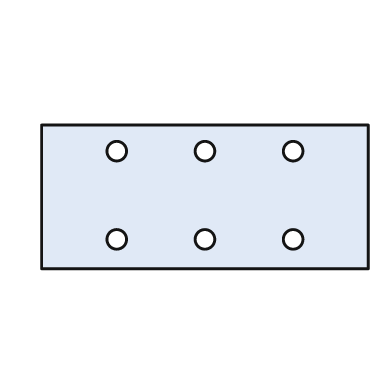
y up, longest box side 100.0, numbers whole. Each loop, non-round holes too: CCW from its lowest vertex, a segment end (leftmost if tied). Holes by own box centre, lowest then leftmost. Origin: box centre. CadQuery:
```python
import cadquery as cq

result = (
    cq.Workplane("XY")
    .moveTo(-50.0, -22.0)
    .lineTo(50.0, -22.0)
    .lineTo(50.0, 22.0)
    .lineTo(-50.0, 22.0)
    .close()
    .moveTo(-27.0, -13.0)
    .circle(3.0)
    .moveTo(0.0, -13.0)
    .circle(3.0)
    .moveTo(27.0, -13.0)
    .circle(3.0)
    .moveTo(-27.0, 14.0)
    .circle(3.0)
    .moveTo(0.0, 14.0)
    .circle(3.0)
    .moveTo(27.0, 14.0)
    .circle(3.0)
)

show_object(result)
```